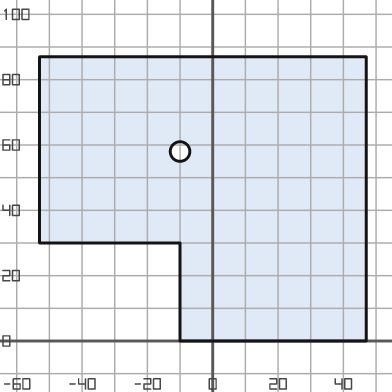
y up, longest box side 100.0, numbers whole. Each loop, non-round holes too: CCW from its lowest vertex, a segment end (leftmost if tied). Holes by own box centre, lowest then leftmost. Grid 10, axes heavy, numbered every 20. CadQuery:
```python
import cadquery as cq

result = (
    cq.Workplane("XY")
    .moveTo(-10.0, 0.0)
    .lineTo(47.0, 0.0)
    .lineTo(47.0, 87.0)
    .lineTo(-53.0, 87.0)
    .lineTo(-53.0, 30.0)
    .lineTo(-10.0, 30.0)
    .close()
    .moveTo(-10.0, 58.0)
    .circle(3.0)
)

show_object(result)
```